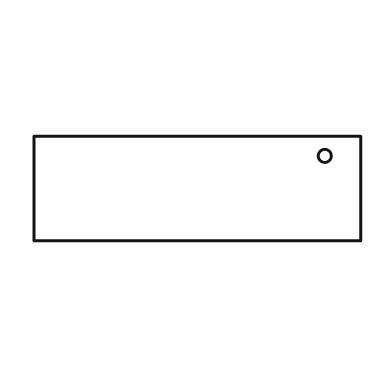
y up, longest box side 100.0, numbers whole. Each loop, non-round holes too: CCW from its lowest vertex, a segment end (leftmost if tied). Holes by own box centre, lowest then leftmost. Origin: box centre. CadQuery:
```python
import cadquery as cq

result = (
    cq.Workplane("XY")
    .moveTo(-50.0, -16.0)
    .lineTo(50.0, -16.0)
    .lineTo(50.0, 16.0)
    .lineTo(-50.0, 16.0)
    .close()
    .moveTo(39.0, 10.0)
    .circle(2.0)
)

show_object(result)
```